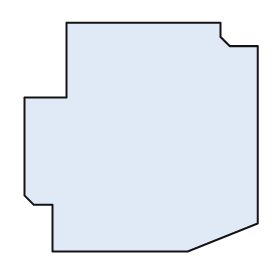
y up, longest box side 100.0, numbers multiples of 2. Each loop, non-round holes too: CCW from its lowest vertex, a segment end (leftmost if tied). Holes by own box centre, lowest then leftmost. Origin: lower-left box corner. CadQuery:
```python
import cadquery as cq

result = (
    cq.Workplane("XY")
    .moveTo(12.0, 0.0)
    .lineTo(70.0, 0.0)
    .lineTo(100.0, 12.0)
    .lineTo(100.0, 88.0)
    .lineTo(88.0, 88.0)
    .lineTo(84.0, 92.0)
    .lineTo(84.0, 98.0)
    .lineTo(18.0, 98.0)
    .lineTo(18.0, 66.0)
    .lineTo(0.0, 66.0)
    .lineTo(0.0, 24.0)
    .lineTo(4.0, 20.0)
    .lineTo(12.0, 20.0)
    .close()
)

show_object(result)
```